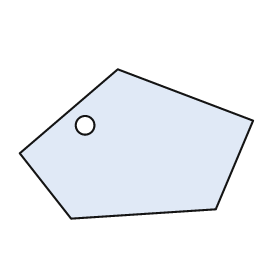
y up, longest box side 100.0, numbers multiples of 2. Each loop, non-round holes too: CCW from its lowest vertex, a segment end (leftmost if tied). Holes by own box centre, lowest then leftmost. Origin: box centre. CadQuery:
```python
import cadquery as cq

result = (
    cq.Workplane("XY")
    .moveTo(-28.0, -32.0)
    .lineTo(34.0, -28.0)
    .lineTo(50.0, 10.0)
    .lineTo(-8.0, 32.0)
    .lineTo(-50.0, -4.0)
    .close()
    .moveTo(-22.0, 8.0)
    .circle(4.0)
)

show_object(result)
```